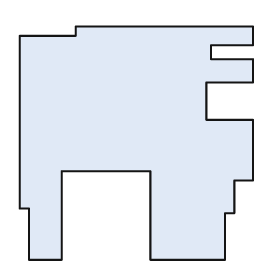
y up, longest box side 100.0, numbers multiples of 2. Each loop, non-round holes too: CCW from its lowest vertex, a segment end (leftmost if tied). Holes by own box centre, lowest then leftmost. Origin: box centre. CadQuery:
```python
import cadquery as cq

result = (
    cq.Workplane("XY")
    .moveTo(-46.0, -50.0)
    .lineTo(-32.0, -50.0)
    .lineTo(-32.0, -12.0)
    .lineTo(6.0, -12.0)
    .lineTo(6.0, -50.0)
    .lineTo(38.0, -50.0)
    .lineTo(38.0, -30.0)
    .lineTo(42.0, -30.0)
    .lineTo(42.0, -16.0)
    .lineTo(50.0, -16.0)
    .lineTo(50.0, 10.0)
    .lineTo(30.0, 10.0)
    .lineTo(30.0, 26.0)
    .lineTo(50.0, 26.0)
    .lineTo(50.0, 36.0)
    .lineTo(32.0, 36.0)
    .lineTo(32.0, 42.0)
    .lineTo(50.0, 42.0)
    .lineTo(50.0, 50.0)
    .lineTo(-26.0, 50.0)
    .lineTo(-26.0, 46.0)
    .lineTo(-50.0, 46.0)
    .lineTo(-50.0, -28.0)
    .lineTo(-46.0, -28.0)
    .close()
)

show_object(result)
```